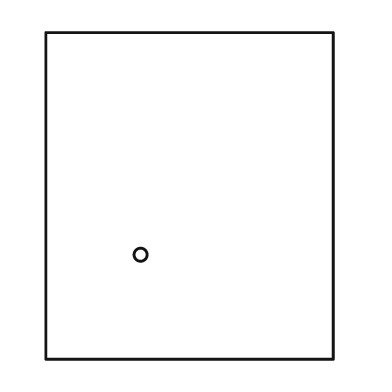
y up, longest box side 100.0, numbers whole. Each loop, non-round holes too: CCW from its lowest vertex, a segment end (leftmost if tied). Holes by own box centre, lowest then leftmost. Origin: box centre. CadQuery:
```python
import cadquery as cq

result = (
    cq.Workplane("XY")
    .moveTo(-44.0, -50.0)
    .lineTo(44.0, -50.0)
    .lineTo(44.0, 50.0)
    .lineTo(-44.0, 50.0)
    .close()
    .moveTo(-15.0, -18.0)
    .circle(2.0)
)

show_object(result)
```